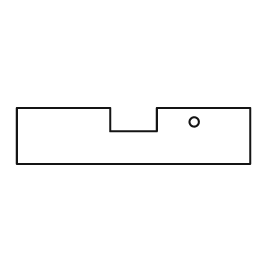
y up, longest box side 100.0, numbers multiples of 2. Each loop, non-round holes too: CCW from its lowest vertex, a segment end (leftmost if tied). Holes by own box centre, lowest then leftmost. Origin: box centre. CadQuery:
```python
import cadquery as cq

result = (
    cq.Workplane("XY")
    .moveTo(-50.0, -12.0)
    .lineTo(50.0, -12.0)
    .lineTo(50.0, 12.0)
    .lineTo(10.0, 12.0)
    .lineTo(10.0, 2.0)
    .lineTo(-10.0, 2.0)
    .lineTo(-10.0, 12.0)
    .lineTo(-50.0, 12.0)
    .close()
    .moveTo(26.0, 6.0)
    .circle(2.0)
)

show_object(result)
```